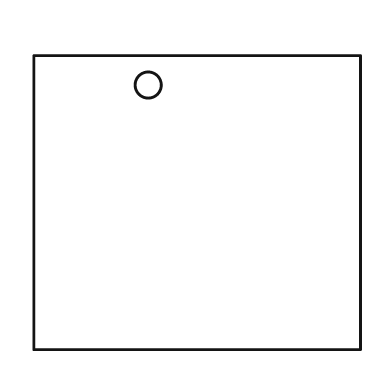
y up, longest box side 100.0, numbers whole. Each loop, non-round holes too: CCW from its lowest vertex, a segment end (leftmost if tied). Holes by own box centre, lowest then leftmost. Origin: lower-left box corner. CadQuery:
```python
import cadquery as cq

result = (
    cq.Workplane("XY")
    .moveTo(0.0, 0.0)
    .lineTo(100.0, 0.0)
    .lineTo(100.0, 90.0)
    .lineTo(0.0, 90.0)
    .close()
    .moveTo(35.0, 81.0)
    .circle(4.0)
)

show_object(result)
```